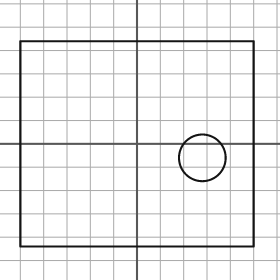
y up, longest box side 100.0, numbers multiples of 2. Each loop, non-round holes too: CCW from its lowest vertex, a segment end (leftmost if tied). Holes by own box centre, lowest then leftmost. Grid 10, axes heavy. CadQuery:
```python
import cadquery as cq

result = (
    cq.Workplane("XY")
    .moveTo(-50.0, -44.0)
    .lineTo(50.0, -44.0)
    .lineTo(50.0, 44.0)
    .lineTo(-50.0, 44.0)
    .close()
    .moveTo(28.0, -6.0)
    .circle(10.0)
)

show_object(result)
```